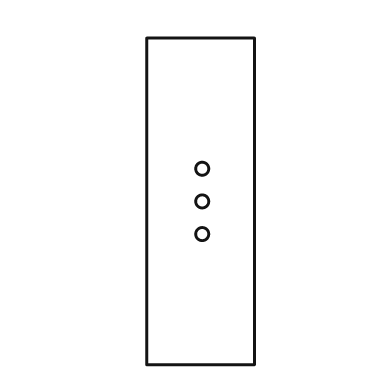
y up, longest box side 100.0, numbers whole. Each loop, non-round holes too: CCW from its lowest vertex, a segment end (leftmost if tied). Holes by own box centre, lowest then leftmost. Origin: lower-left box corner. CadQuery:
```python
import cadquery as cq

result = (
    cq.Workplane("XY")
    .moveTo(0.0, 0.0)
    .lineTo(33.0, 0.0)
    .lineTo(33.0, 100.0)
    .lineTo(0.0, 100.0)
    .close()
    .moveTo(17.0, 40.0)
    .circle(2.0)
    .moveTo(17.0, 50.0)
    .circle(2.0)
    .moveTo(17.0, 60.0)
    .circle(2.0)
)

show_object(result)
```